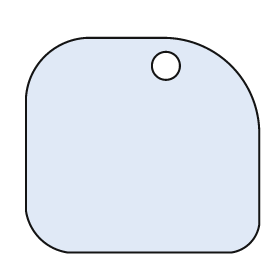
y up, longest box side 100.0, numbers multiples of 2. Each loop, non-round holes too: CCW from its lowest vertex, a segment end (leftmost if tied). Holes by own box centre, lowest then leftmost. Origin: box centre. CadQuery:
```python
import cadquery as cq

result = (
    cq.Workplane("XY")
    .moveTo(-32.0, -46.0)
    .lineTo(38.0, -46.0)
    .threePointArc((46.0, -42.0), (50.0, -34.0))
    .lineTo(50.0, 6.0)
    .threePointArc((38.0, 34.0), (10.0, 46.0))
    .lineTo(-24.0, 46.0)
    .threePointArc((-42.0, 38.0), (-50.0, 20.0))
    .lineTo(-50.0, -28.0)
    .threePointArc((-44.0, -40.0), (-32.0, -46.0))
    .close()
    .moveTo(10.0, 34.0)
    .circle(6.0)
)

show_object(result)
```